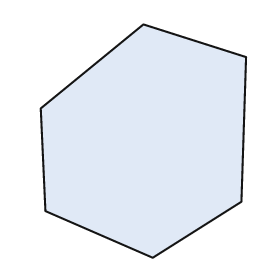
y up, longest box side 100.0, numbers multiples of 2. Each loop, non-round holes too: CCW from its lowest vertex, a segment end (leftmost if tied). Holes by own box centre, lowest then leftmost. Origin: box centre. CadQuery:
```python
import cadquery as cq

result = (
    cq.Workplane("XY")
    .moveTo(4.0, -50.0)
    .lineTo(42.0, -26.0)
    .lineTo(44.0, 36.0)
    .lineTo(0.0, 50.0)
    .lineTo(-44.0, 14.0)
    .lineTo(-42.0, -30.0)
    .close()
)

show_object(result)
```